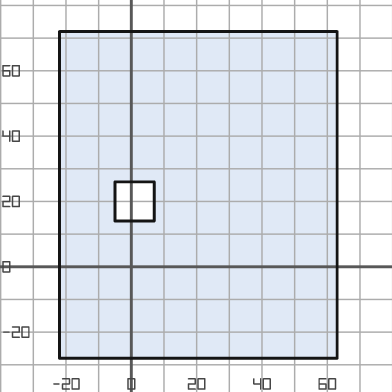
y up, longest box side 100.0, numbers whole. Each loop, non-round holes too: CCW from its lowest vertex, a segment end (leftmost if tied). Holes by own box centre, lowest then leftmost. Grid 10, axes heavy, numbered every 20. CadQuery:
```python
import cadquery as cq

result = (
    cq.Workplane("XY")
    .moveTo(-22.0, -28.0)
    .lineTo(63.0, -28.0)
    .lineTo(63.0, 72.0)
    .lineTo(-22.0, 72.0)
    .close()
    .moveTo(-5.0, 14.0)
    .lineTo(7.0, 14.0)
    .lineTo(7.0, 26.0)
    .lineTo(-5.0, 26.0)
    .close()
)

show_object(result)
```